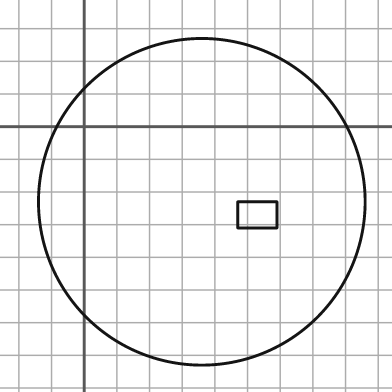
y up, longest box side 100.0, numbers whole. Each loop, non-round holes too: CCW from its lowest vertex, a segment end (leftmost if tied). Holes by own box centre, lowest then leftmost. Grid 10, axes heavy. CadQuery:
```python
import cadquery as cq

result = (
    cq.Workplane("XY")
    .moveTo(36.0, -23.0)
    .circle(50.0)
    .moveTo(47.0, -31.0)
    .lineTo(59.0, -31.0)
    .lineTo(59.0, -23.0)
    .lineTo(47.0, -23.0)
    .close()
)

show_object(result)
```